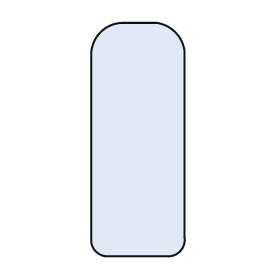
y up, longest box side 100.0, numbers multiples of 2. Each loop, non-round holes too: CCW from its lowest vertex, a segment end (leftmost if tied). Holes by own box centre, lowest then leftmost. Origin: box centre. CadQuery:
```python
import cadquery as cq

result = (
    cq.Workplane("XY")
    .moveTo(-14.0, -50.0)
    .lineTo(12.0, -50.0)
    .threePointArc((18.0, -48.0), (20.0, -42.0))
    .lineTo(20.0, 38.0)
    .threePointArc((16.0, 46.0), (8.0, 50.0))
    .lineTo(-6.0, 50.0)
    .threePointArc((-16.0, 46.0), (-20.0, 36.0))
    .lineTo(-20.0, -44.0)
    .threePointArc((-18.0, -48.0), (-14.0, -50.0))
    .close()
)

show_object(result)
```